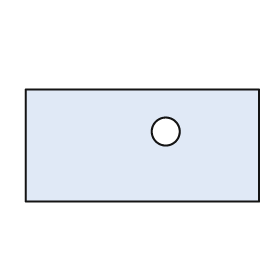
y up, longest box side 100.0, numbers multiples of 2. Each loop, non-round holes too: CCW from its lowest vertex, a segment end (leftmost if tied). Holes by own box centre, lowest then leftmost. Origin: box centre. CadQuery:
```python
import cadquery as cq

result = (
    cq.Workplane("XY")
    .moveTo(-50.0, -24.0)
    .lineTo(50.0, -24.0)
    .lineTo(50.0, 24.0)
    .lineTo(-50.0, 24.0)
    .close()
    .moveTo(10.0, 6.0)
    .circle(6.0)
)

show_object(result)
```